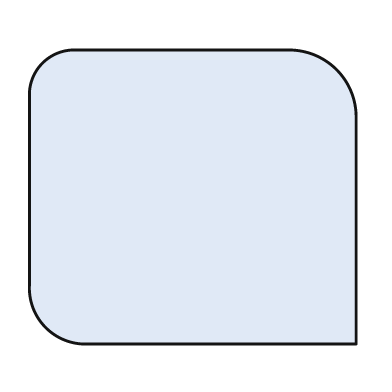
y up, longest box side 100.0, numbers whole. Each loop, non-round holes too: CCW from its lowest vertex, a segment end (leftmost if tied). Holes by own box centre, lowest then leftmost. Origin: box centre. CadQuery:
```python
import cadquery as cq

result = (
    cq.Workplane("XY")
    .moveTo(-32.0, -45.0)
    .lineTo(50.0, -45.0)
    .lineTo(50.0, 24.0)
    .threePointArc((44.0, 39.0), (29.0, 45.0))
    .lineTo(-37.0, 45.0)
    .threePointArc((-46.0, 41.0), (-50.0, 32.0))
    .lineTo(-50.0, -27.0)
    .threePointArc((-45.0, -40.0), (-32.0, -45.0))
    .close()
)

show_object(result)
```